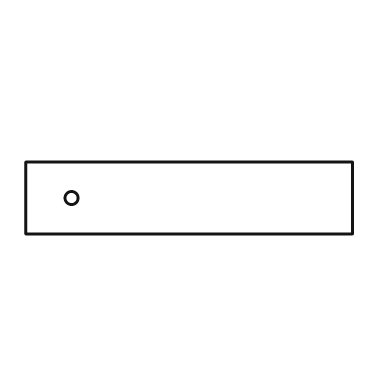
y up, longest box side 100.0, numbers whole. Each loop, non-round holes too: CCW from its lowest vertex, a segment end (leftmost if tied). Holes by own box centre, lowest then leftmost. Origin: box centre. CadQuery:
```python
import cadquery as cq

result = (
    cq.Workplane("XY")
    .moveTo(-50.0, -11.0)
    .lineTo(50.0, -11.0)
    .lineTo(50.0, 11.0)
    .lineTo(-50.0, 11.0)
    .close()
    .moveTo(-36.0, 0.0)
    .circle(2.0)
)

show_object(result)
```